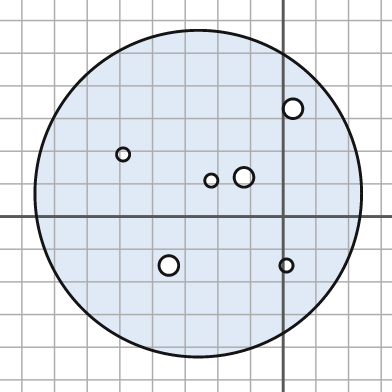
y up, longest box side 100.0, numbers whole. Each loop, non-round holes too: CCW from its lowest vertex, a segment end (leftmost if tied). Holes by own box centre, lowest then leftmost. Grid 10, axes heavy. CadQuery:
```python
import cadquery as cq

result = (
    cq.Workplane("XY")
    .moveTo(-26.0, 7.0)
    .circle(50.0)
    .moveTo(-35.0, -15.0)
    .circle(3.0)
    .moveTo(1.0, -15.0)
    .circle(2.0)
    .moveTo(-22.0, 11.0)
    .circle(2.0)
    .moveTo(-12.0, 12.0)
    .circle(3.0)
    .moveTo(-49.0, 19.0)
    .circle(2.0)
    .moveTo(3.0, 33.0)
    .circle(3.0)
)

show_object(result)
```